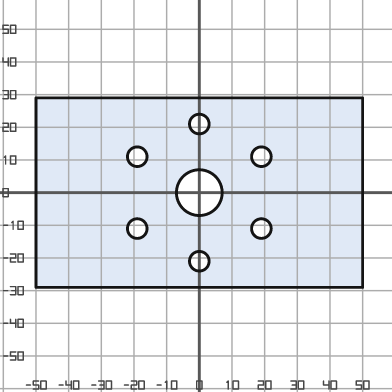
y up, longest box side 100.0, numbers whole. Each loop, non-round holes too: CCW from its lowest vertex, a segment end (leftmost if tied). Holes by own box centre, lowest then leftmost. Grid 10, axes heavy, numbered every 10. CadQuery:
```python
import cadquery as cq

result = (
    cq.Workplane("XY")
    .moveTo(-50.0, -29.0)
    .lineTo(50.0, -29.0)
    .lineTo(50.0, 29.0)
    .lineTo(-50.0, 29.0)
    .close()
    .moveTo(0.0, -21.0)
    .circle(3.0)
    .moveTo(-19.0, -11.0)
    .circle(3.0)
    .moveTo(19.0, -11.0)
    .circle(3.0)
    .moveTo(0.0, 0.0)
    .circle(7.0)
    .moveTo(-19.0, 11.0)
    .circle(3.0)
    .moveTo(19.0, 11.0)
    .circle(3.0)
    .moveTo(0.0, 21.0)
    .circle(3.0)
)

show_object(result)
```